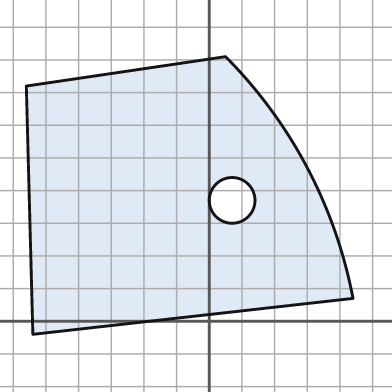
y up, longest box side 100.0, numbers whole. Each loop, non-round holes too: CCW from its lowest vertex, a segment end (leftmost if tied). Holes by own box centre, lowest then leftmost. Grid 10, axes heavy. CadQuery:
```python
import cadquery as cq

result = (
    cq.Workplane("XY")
    .moveTo(-54.0, -4.0)
    .lineTo(44.0, 7.0)
    .threePointArc((30.0, 47.0), (5.0, 81.0))
    .lineTo(-56.0, 72.0)
    .close()
    .moveTo(7.0, 37.0)
    .circle(7.0)
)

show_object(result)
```